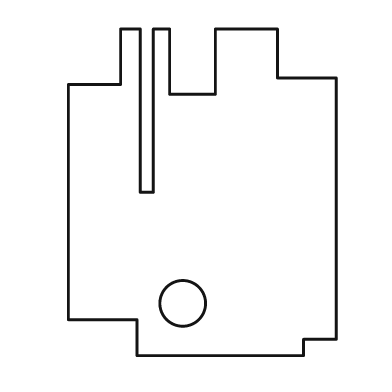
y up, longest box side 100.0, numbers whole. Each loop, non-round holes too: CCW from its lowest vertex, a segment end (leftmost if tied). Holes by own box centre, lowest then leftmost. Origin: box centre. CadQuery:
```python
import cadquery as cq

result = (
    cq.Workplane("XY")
    .moveTo(-20.0, -50.0)
    .lineTo(31.0, -50.0)
    .lineTo(31.0, -45.0)
    .lineTo(41.0, -45.0)
    .lineTo(41.0, 35.0)
    .lineTo(23.0, 35.0)
    .lineTo(23.0, 50.0)
    .lineTo(4.0, 50.0)
    .lineTo(4.0, 30.0)
    .lineTo(-10.0, 30.0)
    .lineTo(-10.0, 50.0)
    .lineTo(-15.0, 50.0)
    .lineTo(-15.0, 0.0)
    .lineTo(-19.0, 0.0)
    .lineTo(-19.0, 50.0)
    .lineTo(-25.0, 50.0)
    .lineTo(-25.0, 33.0)
    .lineTo(-41.0, 33.0)
    .lineTo(-41.0, -39.0)
    .lineTo(-20.0, -39.0)
    .close()
    .moveTo(-6.0, -34.0)
    .circle(7.0)
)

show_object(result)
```